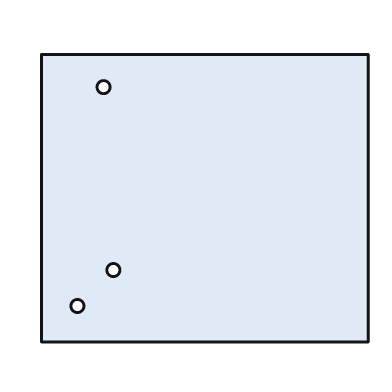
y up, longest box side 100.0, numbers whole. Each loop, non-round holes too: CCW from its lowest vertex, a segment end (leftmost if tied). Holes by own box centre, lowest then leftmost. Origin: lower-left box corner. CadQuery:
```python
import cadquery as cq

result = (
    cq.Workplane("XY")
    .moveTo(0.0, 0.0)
    .lineTo(100.0, 0.0)
    .lineTo(100.0, 88.0)
    .lineTo(0.0, 88.0)
    .close()
    .moveTo(11.0, 11.0)
    .circle(2.0)
    .moveTo(22.0, 22.0)
    .circle(2.0)
    .moveTo(19.0, 78.0)
    .circle(2.0)
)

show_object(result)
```